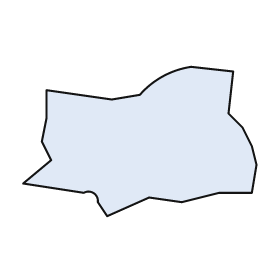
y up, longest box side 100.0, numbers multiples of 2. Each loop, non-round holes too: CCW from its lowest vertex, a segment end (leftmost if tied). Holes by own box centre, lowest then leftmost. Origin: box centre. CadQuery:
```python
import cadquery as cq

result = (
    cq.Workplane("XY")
    .moveTo(-14.0, -32.0)
    .lineTo(4.0, -24.0)
    .lineTo(18.0, -26.0)
    .lineTo(34.0, -22.0)
    .lineTo(48.0, -22.0)
    .lineTo(50.0, -10.0)
    .lineTo(48.0, -2.0)
    .lineTo(44.0, 6.0)
    .lineTo(38.0, 12.0)
    .lineTo(40.0, 30.0)
    .lineTo(22.0, 32.0)
    .threePointArc((10.0, 28.0), (0.0, 20.0))
    .lineTo(-12.0, 18.0)
    .lineTo(-40.0, 22.0)
    .lineTo(-40.0, 10.0)
    .lineTo(-42.0, 0.0)
    .lineTo(-38.0, -8.0)
    .lineTo(-50.0, -18.0)
    .lineTo(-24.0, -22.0)
    .threePointArc((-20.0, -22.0), (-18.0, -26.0))
    .close()
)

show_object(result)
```